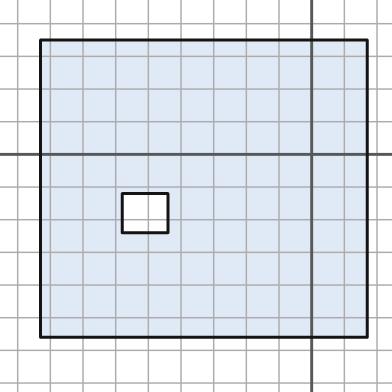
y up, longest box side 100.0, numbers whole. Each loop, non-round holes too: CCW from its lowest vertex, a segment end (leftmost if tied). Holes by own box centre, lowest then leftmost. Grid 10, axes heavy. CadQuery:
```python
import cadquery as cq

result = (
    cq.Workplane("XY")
    .moveTo(-83.0, -56.0)
    .lineTo(17.0, -56.0)
    .lineTo(17.0, 35.0)
    .lineTo(-83.0, 35.0)
    .close()
    .moveTo(-58.0, -24.0)
    .lineTo(-44.0, -24.0)
    .lineTo(-44.0, -12.0)
    .lineTo(-58.0, -12.0)
    .close()
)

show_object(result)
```